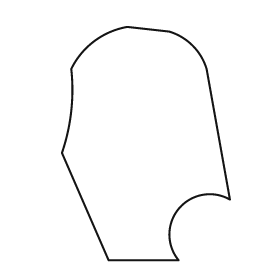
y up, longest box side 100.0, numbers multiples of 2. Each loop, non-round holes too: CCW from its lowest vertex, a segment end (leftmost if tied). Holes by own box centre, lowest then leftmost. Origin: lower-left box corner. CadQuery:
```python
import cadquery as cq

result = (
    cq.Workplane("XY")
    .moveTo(20.0, 0.0)
    .lineTo(50.0, 0.0)
    .threePointArc((50.0, 22.0), (72.0, 26.0))
    .lineTo(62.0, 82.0)
    .threePointArc((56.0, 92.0), (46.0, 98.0))
    .lineTo(28.0, 100.0)
    .threePointArc((14.0, 94.0), (4.0, 82.0))
    .threePointArc((4.0, 64.0), (0.0, 46.0))
    .close()
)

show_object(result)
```